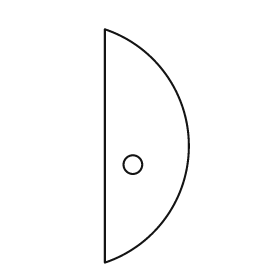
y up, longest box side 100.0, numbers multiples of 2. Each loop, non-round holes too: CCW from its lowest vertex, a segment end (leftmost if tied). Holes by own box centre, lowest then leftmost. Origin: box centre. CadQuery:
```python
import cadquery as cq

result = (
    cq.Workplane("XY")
    .moveTo(-18.0, -50.0)
    .threePointArc((18.0, 0.0), (-18.0, 50.0))
    .close()
    .moveTo(-6.0, -8.0)
    .circle(4.0)
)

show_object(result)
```